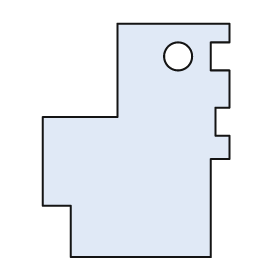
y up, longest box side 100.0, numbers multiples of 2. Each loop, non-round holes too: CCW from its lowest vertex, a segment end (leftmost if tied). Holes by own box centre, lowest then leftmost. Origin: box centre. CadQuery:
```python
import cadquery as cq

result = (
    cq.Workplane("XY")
    .moveTo(-28.0, -50.0)
    .lineTo(32.0, -50.0)
    .lineTo(32.0, -8.0)
    .lineTo(40.0, -8.0)
    .lineTo(40.0, 2.0)
    .lineTo(34.0, 2.0)
    .lineTo(34.0, 14.0)
    .lineTo(40.0, 14.0)
    .lineTo(40.0, 30.0)
    .lineTo(32.0, 30.0)
    .lineTo(32.0, 42.0)
    .lineTo(40.0, 42.0)
    .lineTo(40.0, 50.0)
    .lineTo(-8.0, 50.0)
    .lineTo(-8.0, 10.0)
    .lineTo(-40.0, 10.0)
    .lineTo(-40.0, -28.0)
    .lineTo(-28.0, -28.0)
    .close()
    .moveTo(18.0, 36.0)
    .circle(6.0)
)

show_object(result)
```